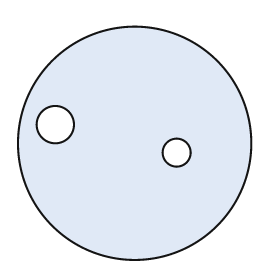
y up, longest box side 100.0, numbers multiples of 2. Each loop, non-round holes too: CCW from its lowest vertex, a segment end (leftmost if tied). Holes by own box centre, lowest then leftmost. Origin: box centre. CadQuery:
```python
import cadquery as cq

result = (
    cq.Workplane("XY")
    .moveTo(0.0, 0.0)
    .circle(50.0)
    .moveTo(18.0, -4.0)
    .circle(6.0)
    .moveTo(-34.0, 8.0)
    .circle(8.0)
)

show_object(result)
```